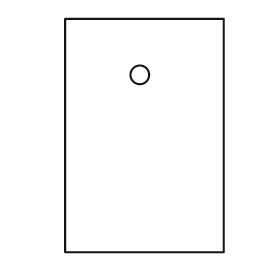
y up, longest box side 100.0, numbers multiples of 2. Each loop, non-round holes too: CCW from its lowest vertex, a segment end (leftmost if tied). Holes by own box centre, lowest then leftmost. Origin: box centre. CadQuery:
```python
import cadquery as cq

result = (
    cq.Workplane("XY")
    .moveTo(-34.0, -50.0)
    .lineTo(34.0, -50.0)
    .lineTo(34.0, 50.0)
    .lineTo(-34.0, 50.0)
    .close()
    .moveTo(-2.0, 26.0)
    .circle(4.0)
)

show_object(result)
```